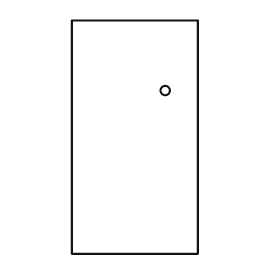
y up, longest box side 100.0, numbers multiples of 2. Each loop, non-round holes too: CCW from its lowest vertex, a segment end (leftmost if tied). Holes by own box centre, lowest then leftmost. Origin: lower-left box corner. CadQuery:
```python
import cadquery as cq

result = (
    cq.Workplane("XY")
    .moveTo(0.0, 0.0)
    .lineTo(54.0, 0.0)
    .lineTo(54.0, 100.0)
    .lineTo(0.0, 100.0)
    .close()
    .moveTo(40.0, 70.0)
    .circle(2.0)
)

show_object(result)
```